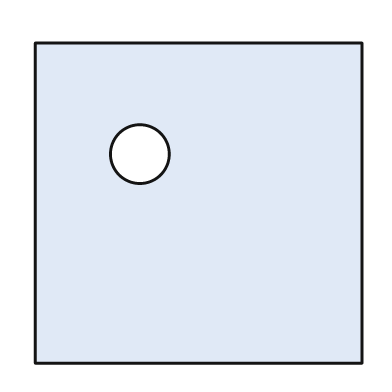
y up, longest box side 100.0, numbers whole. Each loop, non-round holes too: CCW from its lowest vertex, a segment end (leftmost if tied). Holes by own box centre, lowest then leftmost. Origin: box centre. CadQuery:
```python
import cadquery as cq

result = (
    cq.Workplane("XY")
    .moveTo(-50.0, -49.0)
    .lineTo(50.0, -49.0)
    .lineTo(50.0, 49.0)
    .lineTo(-50.0, 49.0)
    .close()
    .moveTo(-18.0, 15.0)
    .circle(9.0)
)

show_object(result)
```